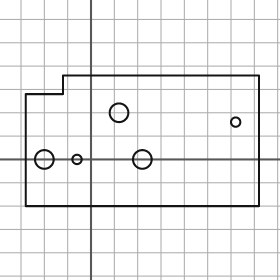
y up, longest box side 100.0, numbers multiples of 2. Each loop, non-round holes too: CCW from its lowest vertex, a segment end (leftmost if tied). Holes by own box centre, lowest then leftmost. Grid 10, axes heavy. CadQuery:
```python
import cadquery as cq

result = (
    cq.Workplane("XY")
    .moveTo(-28.0, -20.0)
    .lineTo(72.0, -20.0)
    .lineTo(72.0, 36.0)
    .lineTo(-12.0, 36.0)
    .lineTo(-12.0, 28.0)
    .lineTo(-28.0, 28.0)
    .close()
    .moveTo(-20.0, 0.0)
    .circle(4.0)
    .moveTo(-6.0, 0.0)
    .circle(2.0)
    .moveTo(22.0, 0.0)
    .circle(4.0)
    .moveTo(62.0, 16.0)
    .circle(2.0)
    .moveTo(12.0, 20.0)
    .circle(4.0)
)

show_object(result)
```